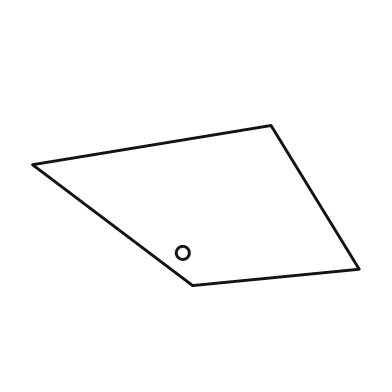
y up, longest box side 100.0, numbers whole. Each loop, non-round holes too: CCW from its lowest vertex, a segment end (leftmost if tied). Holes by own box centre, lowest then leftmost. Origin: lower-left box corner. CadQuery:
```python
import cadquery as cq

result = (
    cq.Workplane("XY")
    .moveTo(49.0, 0.0)
    .lineTo(100.0, 5.0)
    .lineTo(73.0, 49.0)
    .lineTo(0.0, 37.0)
    .close()
    .moveTo(46.0, 10.0)
    .circle(2.0)
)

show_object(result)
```